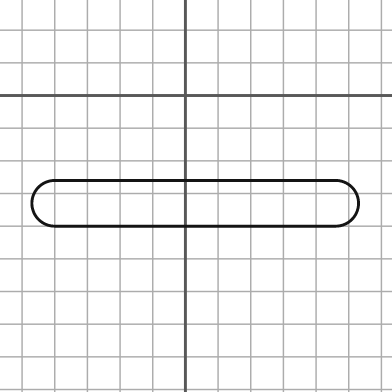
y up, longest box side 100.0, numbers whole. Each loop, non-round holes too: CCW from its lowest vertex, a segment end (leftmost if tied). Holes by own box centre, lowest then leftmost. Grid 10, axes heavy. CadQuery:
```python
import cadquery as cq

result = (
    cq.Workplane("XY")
    .moveTo(-40.0, -40.0)
    .lineTo(46.0, -40.0)
    .threePointArc((53.0, -33.0), (46.0, -26.0))
    .lineTo(-40.0, -26.0)
    .threePointArc((-47.0, -33.0), (-40.0, -40.0))
    .close()
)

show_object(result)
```